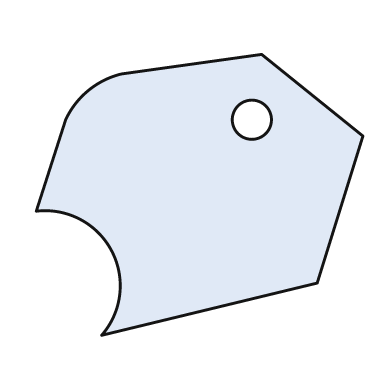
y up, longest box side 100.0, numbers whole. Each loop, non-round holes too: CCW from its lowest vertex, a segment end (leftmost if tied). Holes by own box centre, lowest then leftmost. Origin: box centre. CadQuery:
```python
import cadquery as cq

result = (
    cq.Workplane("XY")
    .moveTo(-30.0, -43.0)
    .lineTo(36.0, -27.0)
    .lineTo(50.0, 18.0)
    .lineTo(19.0, 43.0)
    .lineTo(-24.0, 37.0)
    .threePointArc((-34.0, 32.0), (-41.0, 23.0))
    .lineTo(-50.0, -5.0)
    .threePointArc((-27.0, -17.0), (-30.0, -43.0))
    .close()
    .moveTo(16.0, 23.0)
    .circle(6.0)
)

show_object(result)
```